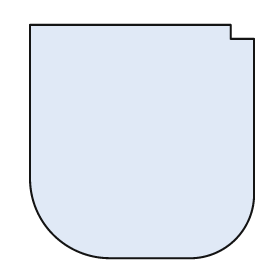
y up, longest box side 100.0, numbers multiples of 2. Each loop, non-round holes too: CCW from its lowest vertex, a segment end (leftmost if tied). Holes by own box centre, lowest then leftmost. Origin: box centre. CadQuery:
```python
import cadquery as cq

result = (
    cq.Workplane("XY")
    .moveTo(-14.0, -50.0)
    .lineTo(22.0, -50.0)
    .threePointArc((40.0, -42.0), (48.0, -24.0))
    .lineTo(48.0, 44.0)
    .lineTo(38.0, 44.0)
    .lineTo(38.0, 50.0)
    .lineTo(-48.0, 50.0)
    .lineTo(-48.0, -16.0)
    .threePointArc((-38.0, -40.0), (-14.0, -50.0))
    .close()
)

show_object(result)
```